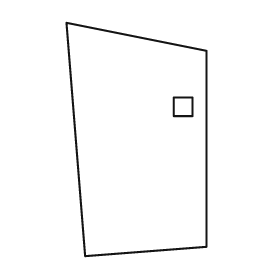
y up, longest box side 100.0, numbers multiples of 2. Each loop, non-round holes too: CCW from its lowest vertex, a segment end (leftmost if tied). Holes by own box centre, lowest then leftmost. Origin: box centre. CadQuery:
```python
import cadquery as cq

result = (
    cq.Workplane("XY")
    .moveTo(-22.0, -50.0)
    .lineTo(30.0, -46.0)
    .lineTo(30.0, 38.0)
    .lineTo(-30.0, 50.0)
    .close()
    .moveTo(16.0, 10.0)
    .lineTo(24.0, 10.0)
    .lineTo(24.0, 18.0)
    .lineTo(16.0, 18.0)
    .close()
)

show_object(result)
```